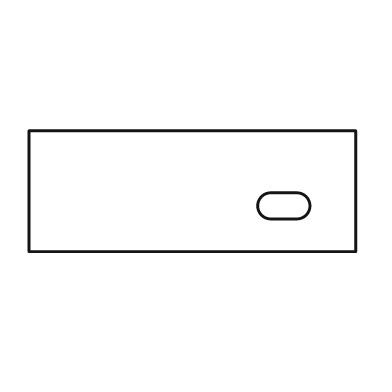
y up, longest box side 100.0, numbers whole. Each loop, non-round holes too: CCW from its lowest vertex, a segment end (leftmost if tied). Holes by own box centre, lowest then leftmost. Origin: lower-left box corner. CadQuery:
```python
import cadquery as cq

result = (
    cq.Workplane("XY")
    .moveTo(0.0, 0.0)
    .lineTo(100.0, 0.0)
    .lineTo(100.0, 37.0)
    .lineTo(0.0, 37.0)
    .close()
    .moveTo(74.0, 10.0)
    .lineTo(82.0, 10.0)
    .threePointArc((86.0, 14.0), (82.0, 18.0))
    .lineTo(74.0, 18.0)
    .threePointArc((70.0, 14.0), (74.0, 10.0))
    .close()
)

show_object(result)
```